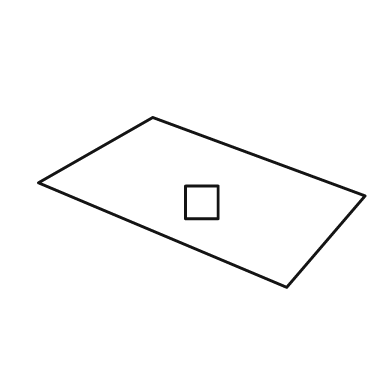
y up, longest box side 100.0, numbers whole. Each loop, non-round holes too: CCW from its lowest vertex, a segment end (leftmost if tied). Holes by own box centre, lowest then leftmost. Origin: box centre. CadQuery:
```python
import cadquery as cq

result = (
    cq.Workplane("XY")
    .moveTo(26.0, -26.0)
    .lineTo(50.0, 2.0)
    .lineTo(-15.0, 26.0)
    .lineTo(-50.0, 6.0)
    .close()
    .moveTo(-5.0, -5.0)
    .lineTo(5.0, -5.0)
    .lineTo(5.0, 5.0)
    .lineTo(-5.0, 5.0)
    .close()
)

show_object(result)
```